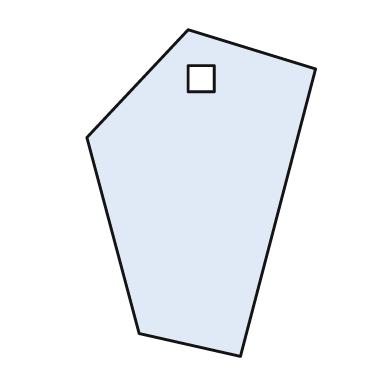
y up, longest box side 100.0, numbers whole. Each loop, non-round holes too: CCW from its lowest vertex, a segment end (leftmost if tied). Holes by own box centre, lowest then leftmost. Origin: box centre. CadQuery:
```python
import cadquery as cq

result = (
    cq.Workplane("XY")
    .moveTo(12.0, -50.0)
    .lineTo(35.0, 38.0)
    .lineTo(-4.0, 50.0)
    .lineTo(-35.0, 17.0)
    .lineTo(-19.0, -43.0)
    .close()
    .moveTo(-4.0, 31.0)
    .lineTo(4.0, 31.0)
    .lineTo(4.0, 39.0)
    .lineTo(-4.0, 39.0)
    .close()
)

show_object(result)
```